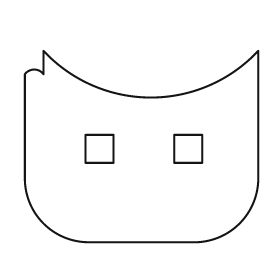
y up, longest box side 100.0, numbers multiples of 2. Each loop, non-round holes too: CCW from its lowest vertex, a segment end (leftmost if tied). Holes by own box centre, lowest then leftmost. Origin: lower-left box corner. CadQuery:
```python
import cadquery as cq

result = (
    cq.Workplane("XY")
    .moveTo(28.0, 0.0)
    .lineTo(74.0, 0.0)
    .threePointArc((92.0, 8.0), (100.0, 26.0))
    .lineTo(100.0, 82.0)
    .threePointArc((54.0, 62.0), (8.0, 82.0))
    .lineTo(8.0, 72.0)
    .threePointArc((4.0, 74.0), (0.0, 72.0))
    .lineTo(0.0, 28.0)
    .threePointArc((8.0, 8.0), (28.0, 0.0))
    .close()
    .moveTo(26.0, 34.0)
    .lineTo(38.0, 34.0)
    .lineTo(38.0, 46.0)
    .lineTo(26.0, 46.0)
    .close()
    .moveTo(64.0, 34.0)
    .lineTo(76.0, 34.0)
    .lineTo(76.0, 46.0)
    .lineTo(64.0, 46.0)
    .close()
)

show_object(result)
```